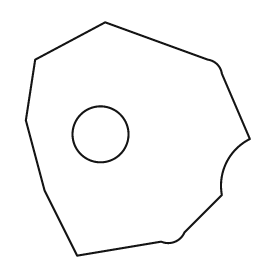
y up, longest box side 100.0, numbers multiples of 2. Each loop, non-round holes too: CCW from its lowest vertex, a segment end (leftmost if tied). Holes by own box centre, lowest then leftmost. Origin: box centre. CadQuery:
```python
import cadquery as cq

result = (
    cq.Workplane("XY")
    .moveTo(-26.0, -50.0)
    .lineTo(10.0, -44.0)
    .threePointArc((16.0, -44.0), (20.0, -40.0))
    .lineTo(36.0, -24.0)
    .threePointArc((38.0, -10.0), (48.0, 0.0))
    .lineTo(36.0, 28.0)
    .threePointArc((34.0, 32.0), (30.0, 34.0))
    .lineTo(-14.0, 50.0)
    .lineTo(-44.0, 34.0)
    .lineTo(-48.0, 8.0)
    .lineTo(-40.0, -22.0)
    .close()
    .moveTo(-16.0, 2.0)
    .circle(12.0)
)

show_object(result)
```